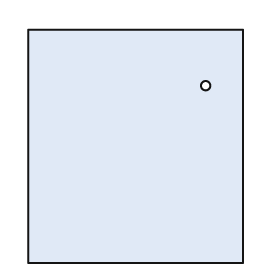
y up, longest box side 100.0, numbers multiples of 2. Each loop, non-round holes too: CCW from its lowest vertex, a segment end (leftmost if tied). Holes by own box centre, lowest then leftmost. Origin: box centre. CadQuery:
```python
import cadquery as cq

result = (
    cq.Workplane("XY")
    .moveTo(-46.0, -50.0)
    .lineTo(46.0, -50.0)
    .lineTo(46.0, 50.0)
    .lineTo(-46.0, 50.0)
    .close()
    .moveTo(30.0, 26.0)
    .circle(2.0)
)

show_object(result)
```